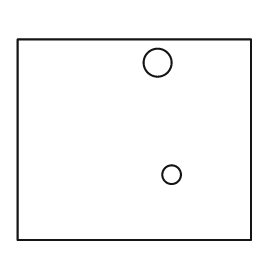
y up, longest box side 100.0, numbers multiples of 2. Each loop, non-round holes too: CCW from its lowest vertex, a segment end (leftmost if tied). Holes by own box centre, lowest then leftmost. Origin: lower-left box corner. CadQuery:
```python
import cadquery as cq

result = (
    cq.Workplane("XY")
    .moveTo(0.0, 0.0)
    .lineTo(100.0, 0.0)
    .lineTo(100.0, 86.0)
    .lineTo(0.0, 86.0)
    .close()
    .moveTo(66.0, 28.0)
    .circle(4.0)
    .moveTo(60.0, 76.0)
    .circle(6.0)
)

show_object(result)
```